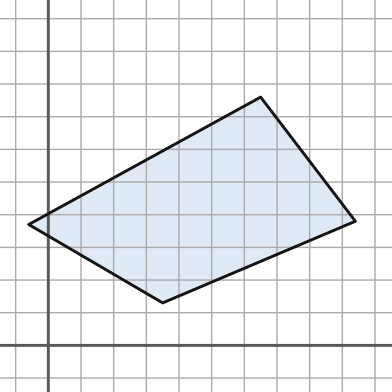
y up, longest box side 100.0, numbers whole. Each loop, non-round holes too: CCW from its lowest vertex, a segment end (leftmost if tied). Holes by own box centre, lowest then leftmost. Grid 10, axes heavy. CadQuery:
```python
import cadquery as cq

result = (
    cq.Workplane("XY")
    .moveTo(35.0, 13.0)
    .lineTo(94.0, 38.0)
    .lineTo(65.0, 76.0)
    .lineTo(-6.0, 37.0)
    .close()
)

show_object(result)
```